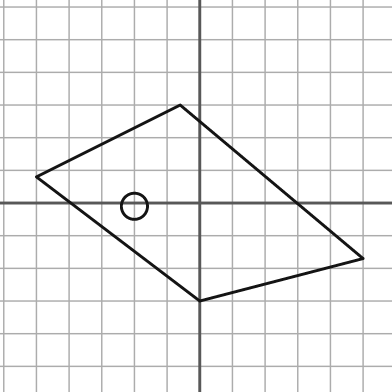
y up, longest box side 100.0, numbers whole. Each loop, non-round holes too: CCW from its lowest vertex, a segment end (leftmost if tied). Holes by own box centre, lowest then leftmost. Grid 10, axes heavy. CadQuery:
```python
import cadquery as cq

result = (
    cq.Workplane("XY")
    .moveTo(0.0, -30.0)
    .lineTo(50.0, -17.0)
    .lineTo(-6.0, 30.0)
    .lineTo(-50.0, 8.0)
    .close()
    .moveTo(-20.0, -1.0)
    .circle(4.0)
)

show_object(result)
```